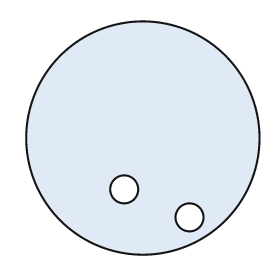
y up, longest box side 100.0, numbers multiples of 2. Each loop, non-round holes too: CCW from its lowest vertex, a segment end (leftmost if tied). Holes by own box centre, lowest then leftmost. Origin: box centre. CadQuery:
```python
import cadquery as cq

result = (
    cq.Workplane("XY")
    .moveTo(0.0, 0.0)
    .circle(50.0)
    .moveTo(20.0, -34.0)
    .circle(6.0)
    .moveTo(-8.0, -22.0)
    .circle(6.0)
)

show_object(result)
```